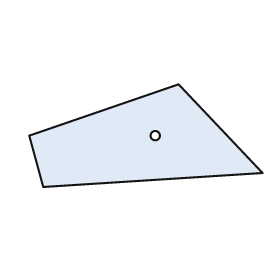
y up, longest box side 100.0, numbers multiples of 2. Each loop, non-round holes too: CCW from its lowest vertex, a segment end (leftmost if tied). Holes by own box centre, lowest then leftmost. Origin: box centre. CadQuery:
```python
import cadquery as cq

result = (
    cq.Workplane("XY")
    .moveTo(-44.0, -22.0)
    .lineTo(50.0, -16.0)
    .lineTo(14.0, 22.0)
    .lineTo(-50.0, 0.0)
    .close()
    .moveTo(4.0, 0.0)
    .circle(2.0)
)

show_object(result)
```